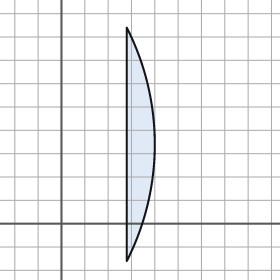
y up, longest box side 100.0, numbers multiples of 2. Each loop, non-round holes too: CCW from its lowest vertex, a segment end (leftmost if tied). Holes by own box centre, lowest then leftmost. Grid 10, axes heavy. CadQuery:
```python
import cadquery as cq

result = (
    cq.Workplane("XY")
    .moveTo(28.0, -16.0)
    .threePointArc((40.0, 34.0), (28.0, 84.0))
    .close()
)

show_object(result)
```